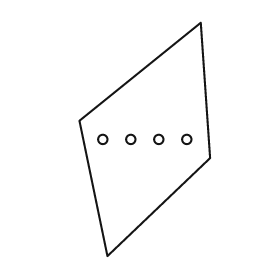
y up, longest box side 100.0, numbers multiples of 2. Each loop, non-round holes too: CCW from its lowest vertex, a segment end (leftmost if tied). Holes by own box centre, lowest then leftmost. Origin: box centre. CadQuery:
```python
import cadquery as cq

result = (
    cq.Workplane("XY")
    .moveTo(-16.0, -50.0)
    .lineTo(28.0, -8.0)
    .lineTo(24.0, 50.0)
    .lineTo(-28.0, 8.0)
    .close()
    .moveTo(-18.0, 0.0)
    .circle(2.0)
    .moveTo(-6.0, 0.0)
    .circle(2.0)
    .moveTo(6.0, 0.0)
    .circle(2.0)
    .moveTo(18.0, 0.0)
    .circle(2.0)
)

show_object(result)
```